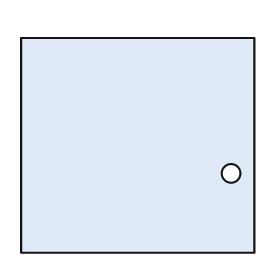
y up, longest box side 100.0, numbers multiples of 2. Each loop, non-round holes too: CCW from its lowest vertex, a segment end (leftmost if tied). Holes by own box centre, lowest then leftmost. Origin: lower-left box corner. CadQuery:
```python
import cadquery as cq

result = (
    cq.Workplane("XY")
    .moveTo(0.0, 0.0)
    .lineTo(100.0, 0.0)
    .lineTo(100.0, 92.0)
    .lineTo(0.0, 92.0)
    .close()
    .moveTo(90.0, 34.0)
    .circle(4.0)
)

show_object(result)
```